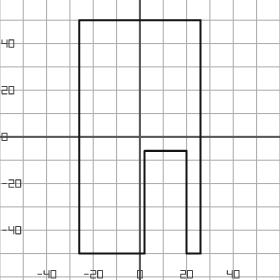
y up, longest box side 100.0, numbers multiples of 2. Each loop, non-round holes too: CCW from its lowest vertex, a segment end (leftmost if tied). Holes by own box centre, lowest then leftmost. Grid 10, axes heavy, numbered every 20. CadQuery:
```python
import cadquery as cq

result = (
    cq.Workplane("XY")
    .moveTo(-26.0, -50.0)
    .lineTo(2.0, -50.0)
    .lineTo(2.0, -6.0)
    .lineTo(20.0, -6.0)
    .lineTo(20.0, -50.0)
    .lineTo(26.0, -50.0)
    .lineTo(26.0, 50.0)
    .lineTo(-26.0, 50.0)
    .close()
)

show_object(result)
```